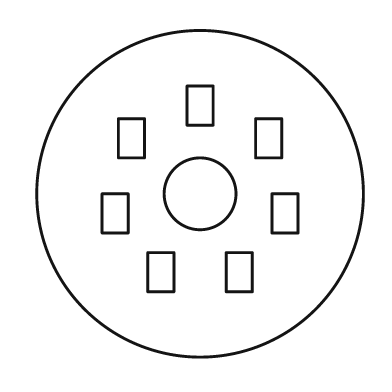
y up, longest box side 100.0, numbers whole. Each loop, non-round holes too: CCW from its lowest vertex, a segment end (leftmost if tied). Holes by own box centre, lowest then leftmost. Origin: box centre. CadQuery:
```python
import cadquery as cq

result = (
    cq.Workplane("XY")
    .moveTo(0.0, 0.0)
    .circle(50.0)
    .moveTo(-16.0, -30.0)
    .lineTo(-8.0, -30.0)
    .lineTo(-8.0, -18.0)
    .lineTo(-16.0, -18.0)
    .close()
    .moveTo(8.0, -30.0)
    .lineTo(16.0, -30.0)
    .lineTo(16.0, -18.0)
    .lineTo(8.0, -18.0)
    .close()
    .moveTo(-30.0, -12.0)
    .lineTo(-22.0, -12.0)
    .lineTo(-22.0, 0.0)
    .lineTo(-30.0, 0.0)
    .close()
    .moveTo(22.0, -12.0)
    .lineTo(30.0, -12.0)
    .lineTo(30.0, 0.0)
    .lineTo(22.0, 0.0)
    .close()
    .moveTo(0.0, 0.0)
    .circle(11.0)
    .moveTo(-25.0, 11.0)
    .lineTo(-17.0, 11.0)
    .lineTo(-17.0, 23.0)
    .lineTo(-25.0, 23.0)
    .close()
    .moveTo(17.0, 11.0)
    .lineTo(25.0, 11.0)
    .lineTo(25.0, 23.0)
    .lineTo(17.0, 23.0)
    .close()
    .moveTo(-4.0, 21.0)
    .lineTo(4.0, 21.0)
    .lineTo(4.0, 33.0)
    .lineTo(-4.0, 33.0)
    .close()
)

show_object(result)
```